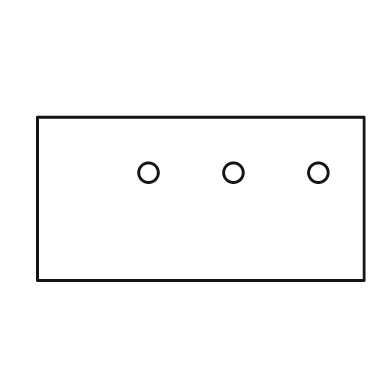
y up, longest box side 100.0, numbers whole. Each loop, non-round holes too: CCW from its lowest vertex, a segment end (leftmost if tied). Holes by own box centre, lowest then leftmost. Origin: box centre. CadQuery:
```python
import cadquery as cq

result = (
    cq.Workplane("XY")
    .moveTo(-50.0, -25.0)
    .lineTo(50.0, -25.0)
    .lineTo(50.0, 25.0)
    .lineTo(-50.0, 25.0)
    .close()
    .moveTo(-16.0, 8.0)
    .circle(3.0)
    .moveTo(10.0, 8.0)
    .circle(3.0)
    .moveTo(36.0, 8.0)
    .circle(3.0)
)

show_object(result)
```